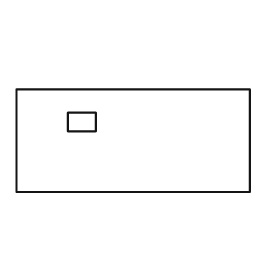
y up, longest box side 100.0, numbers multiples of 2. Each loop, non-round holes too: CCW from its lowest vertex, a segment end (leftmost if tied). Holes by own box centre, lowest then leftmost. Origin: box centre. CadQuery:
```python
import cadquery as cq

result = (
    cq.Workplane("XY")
    .moveTo(-50.0, -22.0)
    .lineTo(50.0, -22.0)
    .lineTo(50.0, 22.0)
    .lineTo(-50.0, 22.0)
    .close()
    .moveTo(-28.0, 4.0)
    .lineTo(-16.0, 4.0)
    .lineTo(-16.0, 12.0)
    .lineTo(-28.0, 12.0)
    .close()
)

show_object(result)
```